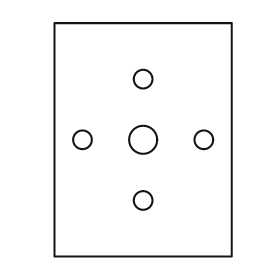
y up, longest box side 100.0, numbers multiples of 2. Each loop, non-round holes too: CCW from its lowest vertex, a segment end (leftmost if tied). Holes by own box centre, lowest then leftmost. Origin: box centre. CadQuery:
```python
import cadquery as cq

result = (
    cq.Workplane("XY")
    .moveTo(-38.0, -50.0)
    .lineTo(38.0, -50.0)
    .lineTo(38.0, 50.0)
    .lineTo(-38.0, 50.0)
    .close()
    .moveTo(0.0, -26.0)
    .circle(4.0)
    .moveTo(-26.0, 0.0)
    .circle(4.0)
    .moveTo(0.0, 0.0)
    .circle(6.0)
    .moveTo(26.0, 0.0)
    .circle(4.0)
    .moveTo(0.0, 26.0)
    .circle(4.0)
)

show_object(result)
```